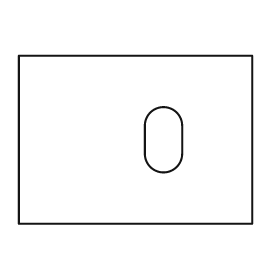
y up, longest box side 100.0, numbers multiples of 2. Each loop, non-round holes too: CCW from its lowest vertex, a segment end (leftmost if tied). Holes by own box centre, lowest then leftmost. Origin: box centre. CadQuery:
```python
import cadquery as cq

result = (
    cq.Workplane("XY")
    .moveTo(-50.0, -36.0)
    .lineTo(50.0, -36.0)
    .lineTo(50.0, 36.0)
    .lineTo(-50.0, 36.0)
    .close()
    .moveTo(4.0, -6.0)
    .threePointArc((12.0, -14.0), (20.0, -6.0))
    .lineTo(20.0, 6.0)
    .threePointArc((12.0, 14.0), (4.0, 6.0))
    .close()
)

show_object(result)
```